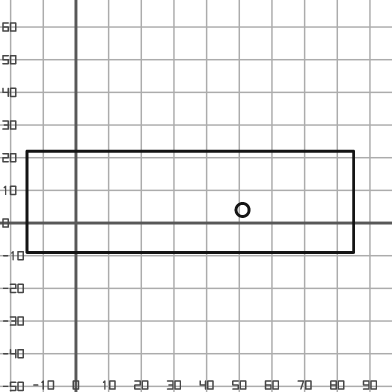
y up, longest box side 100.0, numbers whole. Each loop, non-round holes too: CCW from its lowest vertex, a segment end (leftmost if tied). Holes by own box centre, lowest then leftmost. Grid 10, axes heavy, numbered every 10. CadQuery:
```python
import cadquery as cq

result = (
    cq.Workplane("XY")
    .moveTo(-15.0, -9.0)
    .lineTo(85.0, -9.0)
    .lineTo(85.0, 22.0)
    .lineTo(-15.0, 22.0)
    .close()
    .moveTo(51.0, 4.0)
    .circle(2.0)
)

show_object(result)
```